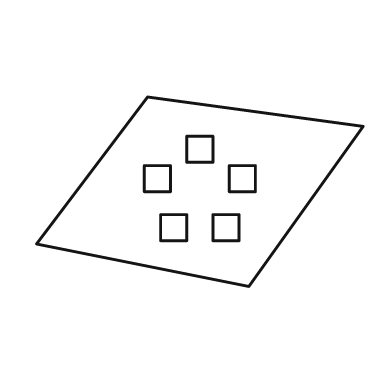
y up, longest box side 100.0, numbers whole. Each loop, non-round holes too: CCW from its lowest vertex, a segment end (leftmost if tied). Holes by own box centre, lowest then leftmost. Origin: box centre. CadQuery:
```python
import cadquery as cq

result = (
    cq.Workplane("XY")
    .moveTo(15.0, -29.0)
    .lineTo(50.0, 20.0)
    .lineTo(-16.0, 29.0)
    .lineTo(-50.0, -16.0)
    .close()
    .moveTo(-12.0, -15.0)
    .lineTo(-4.0, -15.0)
    .lineTo(-4.0, -7.0)
    .lineTo(-12.0, -7.0)
    .close()
    .moveTo(4.0, -15.0)
    .lineTo(12.0, -15.0)
    .lineTo(12.0, -7.0)
    .lineTo(4.0, -7.0)
    .close()
    .moveTo(-17.0, 0.0)
    .lineTo(-9.0, 0.0)
    .lineTo(-9.0, 8.0)
    .lineTo(-17.0, 8.0)
    .close()
    .moveTo(9.0, 0.0)
    .lineTo(17.0, 0.0)
    .lineTo(17.0, 8.0)
    .lineTo(9.0, 8.0)
    .close()
    .moveTo(-4.0, 9.0)
    .lineTo(4.0, 9.0)
    .lineTo(4.0, 17.0)
    .lineTo(-4.0, 17.0)
    .close()
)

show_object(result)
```